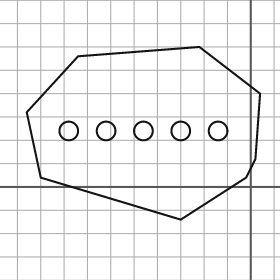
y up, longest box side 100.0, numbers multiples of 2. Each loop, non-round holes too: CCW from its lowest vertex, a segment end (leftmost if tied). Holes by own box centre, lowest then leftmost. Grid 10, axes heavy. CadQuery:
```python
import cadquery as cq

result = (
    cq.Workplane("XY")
    .moveTo(-30.0, -14.0)
    .lineTo(-2.0, 4.0)
    .lineTo(2.0, 12.0)
    .lineTo(4.0, 40.0)
    .lineTo(-22.0, 60.0)
    .lineTo(-74.0, 56.0)
    .lineTo(-96.0, 32.0)
    .lineTo(-90.0, 4.0)
    .close()
    .moveTo(-78.0, 24.0)
    .circle(4.0)
    .moveTo(-62.0, 24.0)
    .circle(4.0)
    .moveTo(-46.0, 24.0)
    .circle(4.0)
    .moveTo(-30.0, 24.0)
    .circle(4.0)
    .moveTo(-14.0, 24.0)
    .circle(4.0)
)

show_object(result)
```